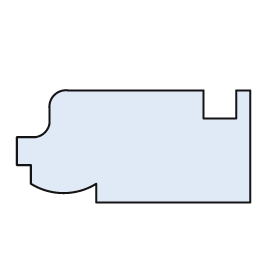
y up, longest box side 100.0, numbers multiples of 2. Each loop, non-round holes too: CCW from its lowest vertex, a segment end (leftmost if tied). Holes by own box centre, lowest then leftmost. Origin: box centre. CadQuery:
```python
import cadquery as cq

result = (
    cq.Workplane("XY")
    .moveTo(-16.0, -24.0)
    .lineTo(50.0, -24.0)
    .lineTo(50.0, 24.0)
    .lineTo(44.0, 24.0)
    .lineTo(44.0, 12.0)
    .lineTo(30.0, 12.0)
    .lineTo(30.0, 24.0)
    .lineTo(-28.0, 24.0)
    .threePointArc((-34.0, 22.0), (-36.0, 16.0))
    .lineTo(-36.0, 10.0)
    .threePointArc((-38.0, 6.0), (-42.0, 4.0))
    .lineTo(-50.0, 4.0)
    .lineTo(-50.0, -8.0)
    .lineTo(-44.0, -8.0)
    .lineTo(-44.0, -16.0)
    .threePointArc((-30.0, -20.0), (-16.0, -16.0))
    .close()
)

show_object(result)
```